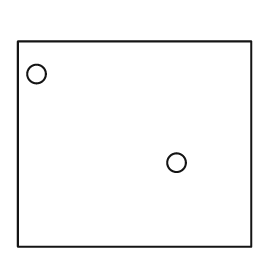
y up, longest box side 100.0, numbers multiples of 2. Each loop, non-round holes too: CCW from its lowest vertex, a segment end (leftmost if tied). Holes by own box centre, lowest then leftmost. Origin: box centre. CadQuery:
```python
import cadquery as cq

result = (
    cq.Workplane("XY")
    .moveTo(-50.0, -44.0)
    .lineTo(50.0, -44.0)
    .lineTo(50.0, 44.0)
    .lineTo(-50.0, 44.0)
    .close()
    .moveTo(18.0, -8.0)
    .circle(4.0)
    .moveTo(-42.0, 30.0)
    .circle(4.0)
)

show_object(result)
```